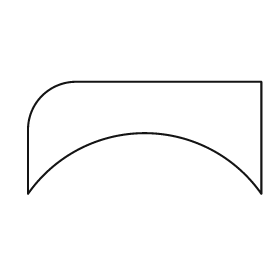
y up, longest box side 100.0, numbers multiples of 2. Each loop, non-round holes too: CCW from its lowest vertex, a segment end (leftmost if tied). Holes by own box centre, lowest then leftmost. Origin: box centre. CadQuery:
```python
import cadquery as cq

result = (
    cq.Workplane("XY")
    .moveTo(-50.0, -24.0)
    .threePointArc((0.0, 2.0), (50.0, -24.0))
    .lineTo(50.0, 24.0)
    .lineTo(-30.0, 24.0)
    .threePointArc((-44.0, 18.0), (-50.0, 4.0))
    .close()
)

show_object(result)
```